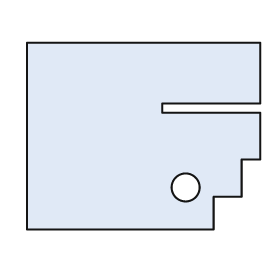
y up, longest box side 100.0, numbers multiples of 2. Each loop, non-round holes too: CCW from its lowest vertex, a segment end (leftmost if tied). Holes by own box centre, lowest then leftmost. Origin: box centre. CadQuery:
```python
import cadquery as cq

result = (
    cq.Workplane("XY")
    .moveTo(-50.0, -40.0)
    .lineTo(30.0, -40.0)
    .lineTo(30.0, -26.0)
    .lineTo(42.0, -26.0)
    .lineTo(42.0, -10.0)
    .lineTo(50.0, -10.0)
    .lineTo(50.0, 10.0)
    .lineTo(8.0, 10.0)
    .lineTo(8.0, 14.0)
    .lineTo(50.0, 14.0)
    .lineTo(50.0, 40.0)
    .lineTo(-50.0, 40.0)
    .close()
    .moveTo(18.0, -22.0)
    .circle(6.0)
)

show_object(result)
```